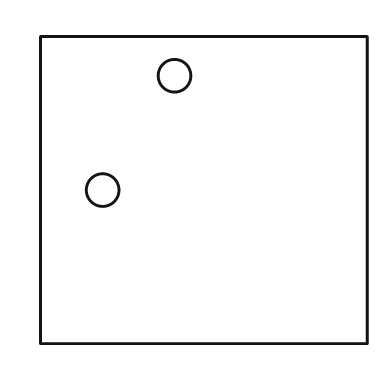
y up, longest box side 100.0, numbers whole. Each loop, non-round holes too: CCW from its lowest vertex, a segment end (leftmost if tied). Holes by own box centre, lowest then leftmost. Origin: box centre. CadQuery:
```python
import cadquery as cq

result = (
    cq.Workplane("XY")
    .moveTo(-50.0, -47.0)
    .lineTo(50.0, -47.0)
    .lineTo(50.0, 47.0)
    .lineTo(-50.0, 47.0)
    .close()
    .moveTo(-31.0, 0.0)
    .circle(5.0)
    .moveTo(-9.0, 35.0)
    .circle(5.0)
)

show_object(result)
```